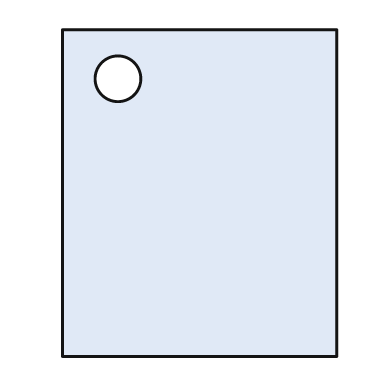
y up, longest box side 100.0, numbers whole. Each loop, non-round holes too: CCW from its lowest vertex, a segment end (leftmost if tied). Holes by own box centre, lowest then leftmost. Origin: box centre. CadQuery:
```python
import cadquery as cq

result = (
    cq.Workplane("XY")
    .moveTo(-42.0, -50.0)
    .lineTo(42.0, -50.0)
    .lineTo(42.0, 50.0)
    .lineTo(-42.0, 50.0)
    .close()
    .moveTo(-25.0, 35.0)
    .circle(7.0)
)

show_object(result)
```